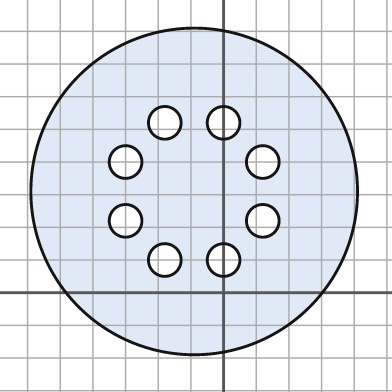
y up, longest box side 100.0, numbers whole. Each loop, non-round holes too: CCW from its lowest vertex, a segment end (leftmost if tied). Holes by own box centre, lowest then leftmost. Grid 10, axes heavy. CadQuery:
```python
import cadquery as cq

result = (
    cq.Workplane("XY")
    .moveTo(-9.0, 31.0)
    .circle(50.0)
    .moveTo(-18.0, 10.0)
    .circle(5.0)
    .moveTo(0.0, 10.0)
    .circle(5.0)
    .moveTo(-30.0, 22.0)
    .circle(5.0)
    .moveTo(12.0, 22.0)
    .circle(5.0)
    .moveTo(-30.0, 40.0)
    .circle(5.0)
    .moveTo(12.0, 40.0)
    .circle(5.0)
    .moveTo(-18.0, 52.0)
    .circle(5.0)
    .moveTo(0.0, 52.0)
    .circle(5.0)
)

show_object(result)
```